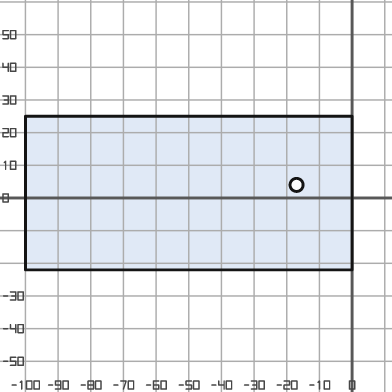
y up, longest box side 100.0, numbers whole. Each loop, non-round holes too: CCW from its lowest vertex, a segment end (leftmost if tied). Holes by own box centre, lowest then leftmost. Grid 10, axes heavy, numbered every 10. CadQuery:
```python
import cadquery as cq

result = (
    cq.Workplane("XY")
    .moveTo(-100.0, -22.0)
    .lineTo(0.0, -22.0)
    .lineTo(0.0, 25.0)
    .lineTo(-100.0, 25.0)
    .close()
    .moveTo(-17.0, 4.0)
    .circle(2.0)
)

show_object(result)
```